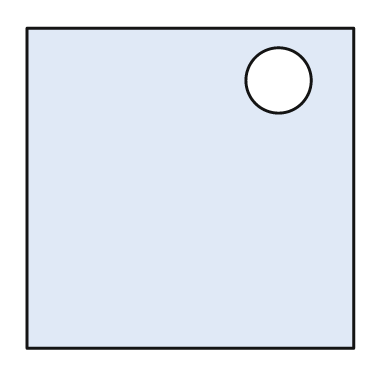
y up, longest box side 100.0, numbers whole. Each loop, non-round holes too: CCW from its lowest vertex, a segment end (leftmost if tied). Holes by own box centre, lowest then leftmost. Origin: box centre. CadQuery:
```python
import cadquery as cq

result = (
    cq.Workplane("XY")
    .moveTo(-50.0, -49.0)
    .lineTo(50.0, -49.0)
    .lineTo(50.0, 49.0)
    .lineTo(-50.0, 49.0)
    .close()
    .moveTo(27.0, 33.0)
    .circle(10.0)
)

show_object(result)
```